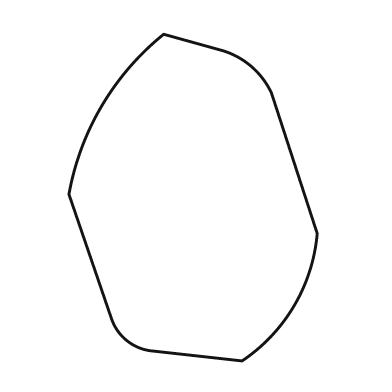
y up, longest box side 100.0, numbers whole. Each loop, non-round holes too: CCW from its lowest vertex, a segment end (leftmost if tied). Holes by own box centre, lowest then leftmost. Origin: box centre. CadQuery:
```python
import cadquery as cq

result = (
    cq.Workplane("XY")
    .moveTo(15.0, -50.0)
    .threePointArc((31.0, -33.0), (38.0, -11.0))
    .lineTo(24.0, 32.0)
    .threePointArc((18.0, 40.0), (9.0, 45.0))
    .lineTo(-9.0, 50.0)
    .threePointArc((-28.0, 28.0), (-38.0, 1.0))
    .lineTo(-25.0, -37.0)
    .threePointArc((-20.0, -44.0), (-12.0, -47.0))
    .close()
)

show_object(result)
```